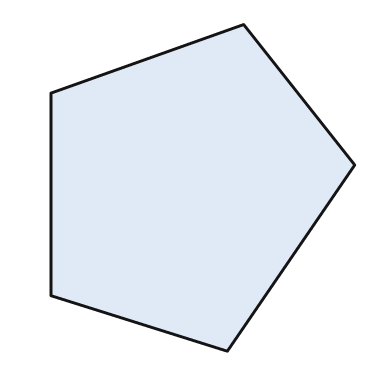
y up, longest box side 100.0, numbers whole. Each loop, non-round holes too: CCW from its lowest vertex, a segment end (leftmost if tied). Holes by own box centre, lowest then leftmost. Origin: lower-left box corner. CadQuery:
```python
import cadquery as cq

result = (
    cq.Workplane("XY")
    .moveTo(54.0, 0.0)
    .lineTo(93.0, 57.0)
    .lineTo(59.0, 100.0)
    .lineTo(0.0, 79.0)
    .lineTo(0.0, 17.0)
    .close()
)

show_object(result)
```